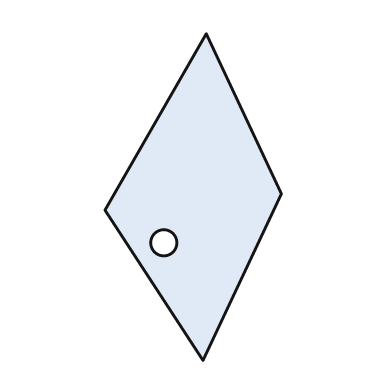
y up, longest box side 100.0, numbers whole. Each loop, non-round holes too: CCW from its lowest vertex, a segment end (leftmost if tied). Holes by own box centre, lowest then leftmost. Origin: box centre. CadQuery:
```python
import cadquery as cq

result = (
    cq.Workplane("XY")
    .moveTo(3.0, -50.0)
    .lineTo(27.0, 1.0)
    .lineTo(4.0, 50.0)
    .lineTo(-27.0, -4.0)
    .close()
    .moveTo(-9.0, -14.0)
    .circle(4.0)
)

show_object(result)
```